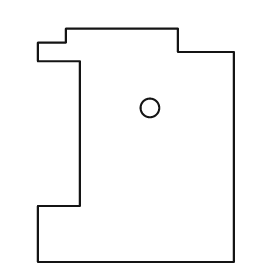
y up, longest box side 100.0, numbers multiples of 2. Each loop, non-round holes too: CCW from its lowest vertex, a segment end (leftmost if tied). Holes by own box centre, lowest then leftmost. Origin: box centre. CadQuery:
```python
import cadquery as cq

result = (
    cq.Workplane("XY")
    .moveTo(-42.0, -50.0)
    .lineTo(42.0, -50.0)
    .lineTo(42.0, 40.0)
    .lineTo(18.0, 40.0)
    .lineTo(18.0, 50.0)
    .lineTo(-30.0, 50.0)
    .lineTo(-30.0, 44.0)
    .lineTo(-42.0, 44.0)
    .lineTo(-42.0, 36.0)
    .lineTo(-24.0, 36.0)
    .lineTo(-24.0, -26.0)
    .lineTo(-42.0, -26.0)
    .close()
    .moveTo(6.0, 16.0)
    .circle(4.0)
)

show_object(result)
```